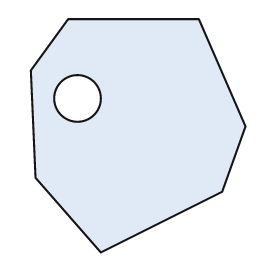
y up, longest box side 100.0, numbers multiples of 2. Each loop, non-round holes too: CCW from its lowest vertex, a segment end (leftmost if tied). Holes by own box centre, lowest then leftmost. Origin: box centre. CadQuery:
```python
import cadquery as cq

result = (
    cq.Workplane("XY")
    .moveTo(-16.0, -50.0)
    .lineTo(36.0, -24.0)
    .lineTo(46.0, 4.0)
    .lineTo(26.0, 50.0)
    .lineTo(-30.0, 50.0)
    .lineTo(-46.0, 28.0)
    .lineTo(-44.0, -18.0)
    .close()
    .moveTo(-26.0, 16.0)
    .circle(10.0)
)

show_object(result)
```